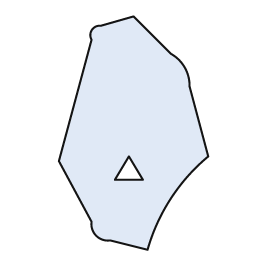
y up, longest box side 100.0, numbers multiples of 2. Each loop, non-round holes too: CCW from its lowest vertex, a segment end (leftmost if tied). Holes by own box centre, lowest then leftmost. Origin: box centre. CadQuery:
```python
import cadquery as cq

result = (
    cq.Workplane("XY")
    .moveTo(6.0, -50.0)
    .threePointArc((16.0, -28.0), (32.0, -10.0))
    .lineTo(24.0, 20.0)
    .threePointArc((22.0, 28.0), (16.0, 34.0))
    .lineTo(0.0, 50.0)
    .lineTo(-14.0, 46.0)
    .threePointArc((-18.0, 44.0), (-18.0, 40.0))
    .lineTo(-32.0, -12.0)
    .lineTo(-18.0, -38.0)
    .threePointArc((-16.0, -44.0), (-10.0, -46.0))
    .close()
    .moveTo(-8.0, -20.0)
    .lineTo(4.0, -20.0)
    .lineTo(-2.0, -10.0)
    .close()
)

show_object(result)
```